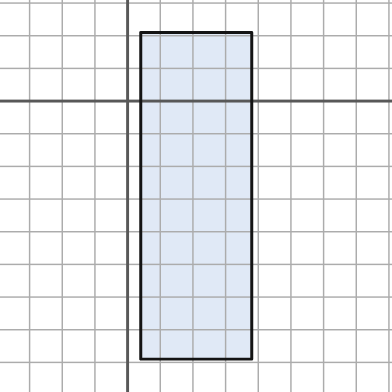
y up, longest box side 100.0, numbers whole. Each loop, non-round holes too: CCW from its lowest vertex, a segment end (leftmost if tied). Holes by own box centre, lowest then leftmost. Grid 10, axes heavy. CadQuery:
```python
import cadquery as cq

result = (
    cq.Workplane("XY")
    .moveTo(4.0, -79.0)
    .lineTo(38.0, -79.0)
    .lineTo(38.0, 21.0)
    .lineTo(4.0, 21.0)
    .close()
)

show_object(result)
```